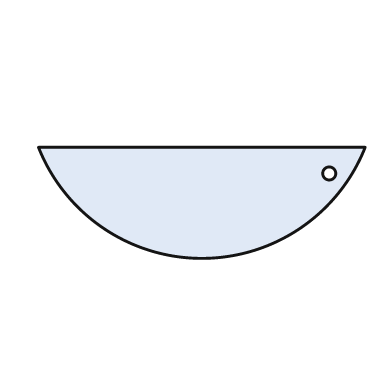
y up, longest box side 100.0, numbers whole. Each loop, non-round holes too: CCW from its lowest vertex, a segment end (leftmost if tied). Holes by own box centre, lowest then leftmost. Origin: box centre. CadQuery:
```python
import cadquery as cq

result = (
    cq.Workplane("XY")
    .moveTo(-50.0, 17.0)
    .threePointArc((0.0, -17.0), (50.0, 17.0))
    .close()
    .moveTo(39.0, 9.0)
    .circle(2.0)
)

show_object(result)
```